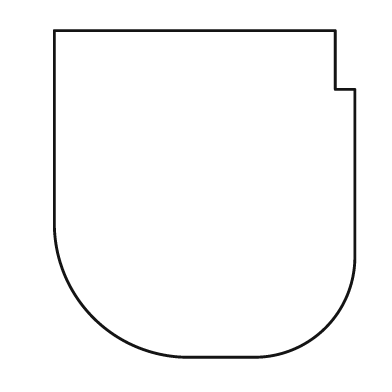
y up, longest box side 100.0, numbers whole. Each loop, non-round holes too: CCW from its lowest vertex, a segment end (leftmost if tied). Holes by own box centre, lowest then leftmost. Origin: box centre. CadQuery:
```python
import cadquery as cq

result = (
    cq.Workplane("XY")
    .moveTo(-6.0, -50.0)
    .lineTo(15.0, -50.0)
    .threePointArc((37.0, -41.0), (46.0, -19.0))
    .lineTo(46.0, 32.0)
    .lineTo(40.0, 32.0)
    .lineTo(40.0, 50.0)
    .lineTo(-46.0, 50.0)
    .lineTo(-46.0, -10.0)
    .threePointArc((-34.0, -38.0), (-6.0, -50.0))
    .close()
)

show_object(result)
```